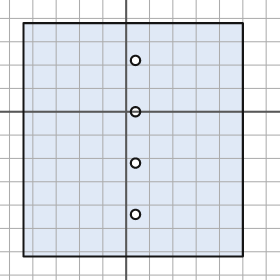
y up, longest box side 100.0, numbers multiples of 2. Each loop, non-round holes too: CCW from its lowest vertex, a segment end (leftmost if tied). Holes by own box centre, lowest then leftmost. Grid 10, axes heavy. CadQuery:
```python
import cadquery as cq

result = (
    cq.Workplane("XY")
    .moveTo(-44.0, -62.0)
    .lineTo(50.0, -62.0)
    .lineTo(50.0, 38.0)
    .lineTo(-44.0, 38.0)
    .close()
    .moveTo(4.0, -44.0)
    .circle(2.0)
    .moveTo(4.0, -22.0)
    .circle(2.0)
    .moveTo(4.0, 0.0)
    .circle(2.0)
    .moveTo(4.0, 22.0)
    .circle(2.0)
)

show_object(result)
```